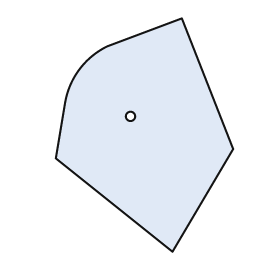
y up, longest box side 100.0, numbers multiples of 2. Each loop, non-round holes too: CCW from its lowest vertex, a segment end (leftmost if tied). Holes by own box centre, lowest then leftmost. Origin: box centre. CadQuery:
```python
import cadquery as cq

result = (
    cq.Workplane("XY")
    .moveTo(12.0, -50.0)
    .lineTo(38.0, -6.0)
    .lineTo(16.0, 50.0)
    .lineTo(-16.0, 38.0)
    .threePointArc((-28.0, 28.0), (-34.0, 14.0))
    .lineTo(-38.0, -10.0)
    .close()
    .moveTo(-6.0, 8.0)
    .circle(2.0)
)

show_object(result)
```